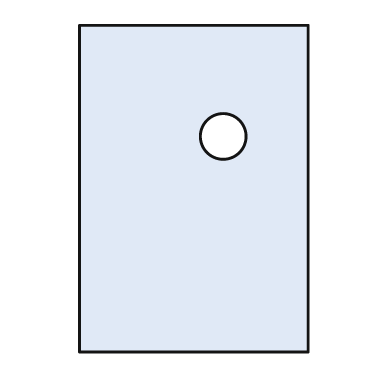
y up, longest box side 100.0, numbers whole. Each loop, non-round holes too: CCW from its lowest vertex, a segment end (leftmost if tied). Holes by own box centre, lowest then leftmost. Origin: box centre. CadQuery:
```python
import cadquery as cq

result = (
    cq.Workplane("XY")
    .moveTo(-35.0, -50.0)
    .lineTo(35.0, -50.0)
    .lineTo(35.0, 50.0)
    .lineTo(-35.0, 50.0)
    .close()
    .moveTo(9.0, 16.0)
    .circle(7.0)
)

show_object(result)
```